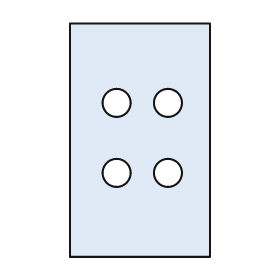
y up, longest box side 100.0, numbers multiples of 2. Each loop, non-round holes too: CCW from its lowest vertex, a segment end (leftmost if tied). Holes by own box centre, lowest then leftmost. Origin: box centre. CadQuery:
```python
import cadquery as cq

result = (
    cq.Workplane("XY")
    .moveTo(-30.0, -50.0)
    .lineTo(30.0, -50.0)
    .lineTo(30.0, 50.0)
    .lineTo(-30.0, 50.0)
    .close()
    .moveTo(-10.0, -14.0)
    .circle(6.0)
    .moveTo(12.0, -14.0)
    .circle(6.0)
    .moveTo(-10.0, 16.0)
    .circle(6.0)
    .moveTo(12.0, 16.0)
    .circle(6.0)
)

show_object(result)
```